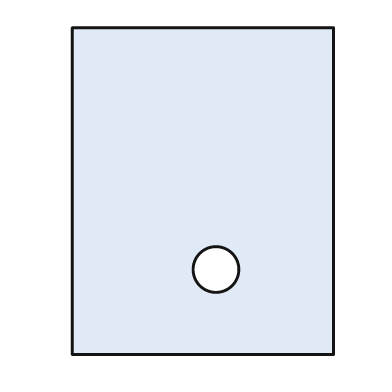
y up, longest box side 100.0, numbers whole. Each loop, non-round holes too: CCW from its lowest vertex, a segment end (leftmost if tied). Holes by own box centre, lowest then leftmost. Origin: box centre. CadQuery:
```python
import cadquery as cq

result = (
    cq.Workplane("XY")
    .moveTo(-40.0, -50.0)
    .lineTo(40.0, -50.0)
    .lineTo(40.0, 50.0)
    .lineTo(-40.0, 50.0)
    .close()
    .moveTo(4.0, -24.0)
    .circle(7.0)
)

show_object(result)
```